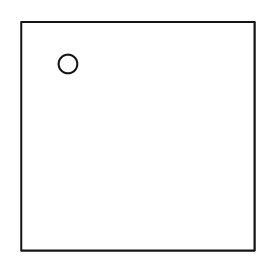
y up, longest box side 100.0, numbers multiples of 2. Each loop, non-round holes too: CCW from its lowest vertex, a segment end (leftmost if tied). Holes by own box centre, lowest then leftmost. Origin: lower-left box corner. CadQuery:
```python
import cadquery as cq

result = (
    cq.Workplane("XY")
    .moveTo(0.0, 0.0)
    .lineTo(100.0, 0.0)
    .lineTo(100.0, 98.0)
    .lineTo(0.0, 98.0)
    .close()
    .moveTo(20.0, 80.0)
    .circle(4.0)
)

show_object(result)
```